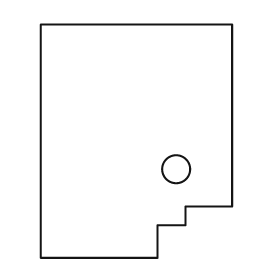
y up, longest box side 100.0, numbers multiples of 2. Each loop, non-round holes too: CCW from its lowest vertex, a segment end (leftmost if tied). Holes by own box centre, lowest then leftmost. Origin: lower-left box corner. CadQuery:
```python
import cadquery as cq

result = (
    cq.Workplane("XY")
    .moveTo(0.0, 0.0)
    .lineTo(50.0, 0.0)
    .lineTo(50.0, 14.0)
    .lineTo(62.0, 14.0)
    .lineTo(62.0, 22.0)
    .lineTo(82.0, 22.0)
    .lineTo(82.0, 100.0)
    .lineTo(0.0, 100.0)
    .close()
    .moveTo(58.0, 38.0)
    .circle(6.0)
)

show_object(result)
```